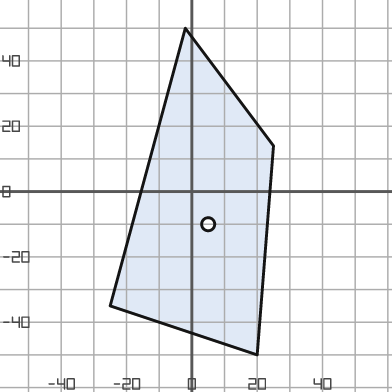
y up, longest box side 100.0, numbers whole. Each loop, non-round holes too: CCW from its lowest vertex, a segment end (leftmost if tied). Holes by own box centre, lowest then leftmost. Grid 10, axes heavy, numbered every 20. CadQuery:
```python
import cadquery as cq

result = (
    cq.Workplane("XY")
    .moveTo(20.0, -50.0)
    .lineTo(25.0, 14.0)
    .lineTo(-2.0, 50.0)
    .lineTo(-25.0, -35.0)
    .close()
    .moveTo(5.0, -10.0)
    .circle(2.0)
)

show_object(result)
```